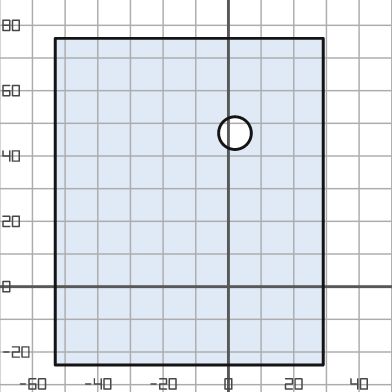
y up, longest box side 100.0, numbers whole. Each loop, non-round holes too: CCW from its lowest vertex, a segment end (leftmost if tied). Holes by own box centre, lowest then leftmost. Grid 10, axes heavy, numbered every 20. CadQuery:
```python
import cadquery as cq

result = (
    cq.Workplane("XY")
    .moveTo(-53.0, -24.0)
    .lineTo(29.0, -24.0)
    .lineTo(29.0, 76.0)
    .lineTo(-53.0, 76.0)
    .close()
    .moveTo(2.0, 47.0)
    .circle(5.0)
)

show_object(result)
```